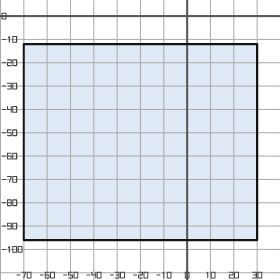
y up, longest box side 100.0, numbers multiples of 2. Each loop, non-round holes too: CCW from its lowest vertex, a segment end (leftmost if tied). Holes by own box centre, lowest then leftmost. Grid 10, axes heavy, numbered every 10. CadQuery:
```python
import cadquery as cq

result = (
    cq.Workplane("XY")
    .moveTo(-70.0, -96.0)
    .lineTo(30.0, -96.0)
    .lineTo(30.0, -12.0)
    .lineTo(-70.0, -12.0)
    .close()
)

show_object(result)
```